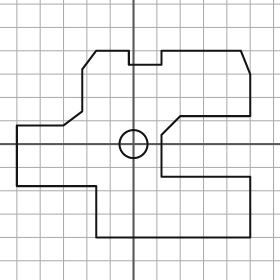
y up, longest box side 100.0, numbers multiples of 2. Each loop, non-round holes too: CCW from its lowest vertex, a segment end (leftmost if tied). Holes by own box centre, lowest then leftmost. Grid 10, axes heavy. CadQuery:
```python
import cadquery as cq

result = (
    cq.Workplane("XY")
    .moveTo(-16.0, -40.0)
    .lineTo(50.0, -40.0)
    .lineTo(50.0, -14.0)
    .lineTo(12.0, -14.0)
    .lineTo(12.0, 4.0)
    .lineTo(20.0, 12.0)
    .lineTo(50.0, 12.0)
    .lineTo(50.0, 30.0)
    .lineTo(46.0, 40.0)
    .lineTo(12.0, 40.0)
    .lineTo(12.0, 34.0)
    .lineTo(-2.0, 34.0)
    .lineTo(-2.0, 40.0)
    .lineTo(-16.0, 40.0)
    .lineTo(-22.0, 32.0)
    .lineTo(-22.0, 14.0)
    .lineTo(-30.0, 8.0)
    .lineTo(-50.0, 8.0)
    .lineTo(-50.0, -18.0)
    .lineTo(-16.0, -18.0)
    .close()
    .moveTo(0.0, 0.0)
    .circle(6.0)
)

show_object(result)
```